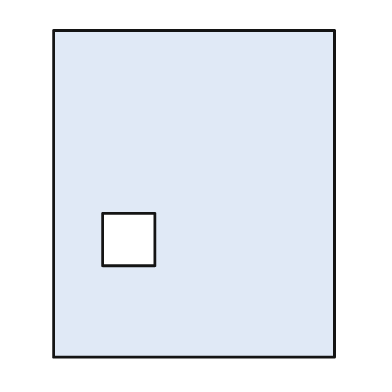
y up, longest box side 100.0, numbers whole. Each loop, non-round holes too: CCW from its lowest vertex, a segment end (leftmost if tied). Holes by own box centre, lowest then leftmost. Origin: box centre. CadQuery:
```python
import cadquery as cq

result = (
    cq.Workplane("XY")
    .moveTo(-43.0, -50.0)
    .lineTo(43.0, -50.0)
    .lineTo(43.0, 50.0)
    .lineTo(-43.0, 50.0)
    .close()
    .moveTo(-28.0, -22.0)
    .lineTo(-12.0, -22.0)
    .lineTo(-12.0, -6.0)
    .lineTo(-28.0, -6.0)
    .close()
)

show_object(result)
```